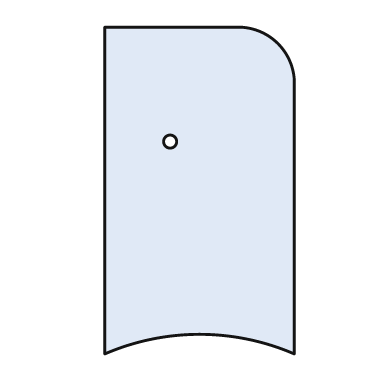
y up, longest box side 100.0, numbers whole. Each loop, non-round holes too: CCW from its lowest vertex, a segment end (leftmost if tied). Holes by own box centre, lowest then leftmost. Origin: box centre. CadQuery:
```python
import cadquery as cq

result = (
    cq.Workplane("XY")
    .moveTo(-29.0, -50.0)
    .threePointArc((0.0, -44.0), (29.0, -50.0))
    .lineTo(29.0, 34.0)
    .threePointArc((24.0, 45.0), (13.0, 50.0))
    .lineTo(-29.0, 50.0)
    .close()
    .moveTo(-9.0, 15.0)
    .circle(2.0)
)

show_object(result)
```